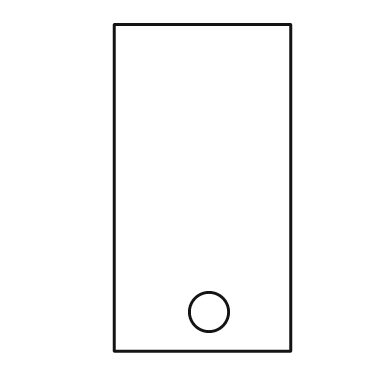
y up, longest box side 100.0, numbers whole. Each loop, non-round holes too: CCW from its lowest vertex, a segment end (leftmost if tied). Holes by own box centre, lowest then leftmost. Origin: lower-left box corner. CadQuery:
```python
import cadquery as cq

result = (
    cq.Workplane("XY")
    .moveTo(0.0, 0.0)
    .lineTo(54.0, 0.0)
    .lineTo(54.0, 100.0)
    .lineTo(0.0, 100.0)
    .close()
    .moveTo(29.0, 12.0)
    .circle(6.0)
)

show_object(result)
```